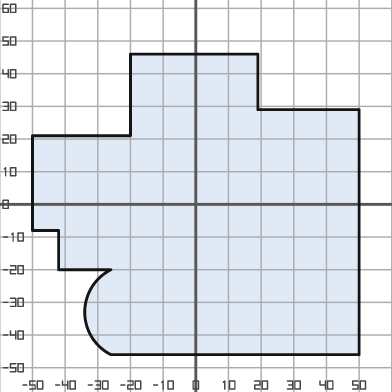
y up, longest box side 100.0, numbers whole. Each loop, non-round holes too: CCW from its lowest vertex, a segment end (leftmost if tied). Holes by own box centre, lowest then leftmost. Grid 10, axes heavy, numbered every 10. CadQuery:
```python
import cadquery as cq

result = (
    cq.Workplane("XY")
    .moveTo(-26.0, -46.0)
    .lineTo(50.0, -46.0)
    .lineTo(50.0, 29.0)
    .lineTo(19.0, 29.0)
    .lineTo(19.0, 46.0)
    .lineTo(-20.0, 46.0)
    .lineTo(-20.0, 21.0)
    .lineTo(-50.0, 21.0)
    .lineTo(-50.0, -8.0)
    .lineTo(-42.0, -8.0)
    .lineTo(-42.0, -20.0)
    .lineTo(-26.0, -20.0)
    .threePointArc((-34.0, -33.0), (-26.0, -46.0))
    .close()
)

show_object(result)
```